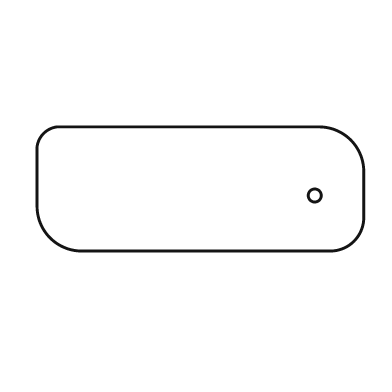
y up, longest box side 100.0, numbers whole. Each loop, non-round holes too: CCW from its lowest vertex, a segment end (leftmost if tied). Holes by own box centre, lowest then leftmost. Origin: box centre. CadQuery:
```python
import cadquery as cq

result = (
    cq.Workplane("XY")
    .moveTo(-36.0, -19.0)
    .lineTo(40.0, -19.0)
    .threePointArc((47.0, -16.0), (50.0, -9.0))
    .lineTo(50.0, 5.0)
    .threePointArc((46.0, 15.0), (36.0, 19.0))
    .lineTo(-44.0, 19.0)
    .threePointArc((-48.0, 17.0), (-50.0, 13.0))
    .lineTo(-50.0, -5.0)
    .threePointArc((-46.0, -15.0), (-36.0, -19.0))
    .close()
    .moveTo(35.0, -2.0)
    .circle(2.0)
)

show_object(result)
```